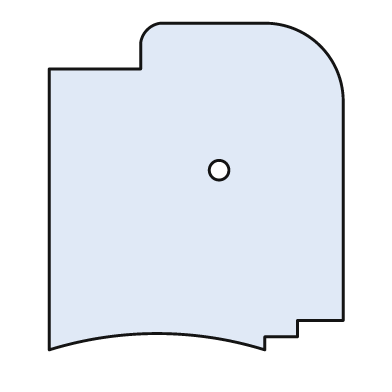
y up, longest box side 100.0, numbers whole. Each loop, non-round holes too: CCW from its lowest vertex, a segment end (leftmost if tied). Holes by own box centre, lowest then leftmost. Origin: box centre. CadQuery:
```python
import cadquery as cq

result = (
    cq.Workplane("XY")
    .moveTo(-45.0, -50.0)
    .threePointArc((-12.0, -45.0), (21.0, -50.0))
    .lineTo(21.0, -46.0)
    .lineTo(31.0, -46.0)
    .lineTo(31.0, -41.0)
    .lineTo(45.0, -41.0)
    .lineTo(45.0, 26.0)
    .threePointArc((38.0, 43.0), (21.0, 50.0))
    .lineTo(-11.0, 50.0)
    .threePointArc((-15.0, 48.0), (-17.0, 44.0))
    .lineTo(-17.0, 36.0)
    .lineTo(-45.0, 36.0)
    .close()
    .moveTo(7.0, 5.0)
    .circle(3.0)
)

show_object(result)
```